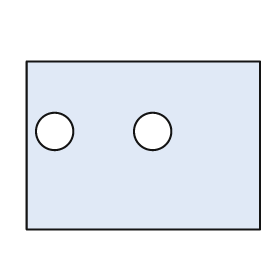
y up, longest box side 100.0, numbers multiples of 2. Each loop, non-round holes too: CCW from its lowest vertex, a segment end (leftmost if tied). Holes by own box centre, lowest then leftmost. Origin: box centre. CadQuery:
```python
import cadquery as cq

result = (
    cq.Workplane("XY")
    .moveTo(-50.0, -36.0)
    .lineTo(50.0, -36.0)
    .lineTo(50.0, 36.0)
    .lineTo(-50.0, 36.0)
    .close()
    .moveTo(-38.0, 6.0)
    .circle(8.0)
    .moveTo(4.0, 6.0)
    .circle(8.0)
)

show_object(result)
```